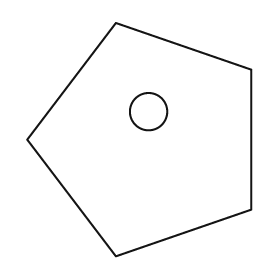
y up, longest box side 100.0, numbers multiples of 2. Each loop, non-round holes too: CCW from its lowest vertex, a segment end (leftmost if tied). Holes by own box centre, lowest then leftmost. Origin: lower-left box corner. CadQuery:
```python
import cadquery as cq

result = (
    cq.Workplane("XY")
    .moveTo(38.0, 0.0)
    .lineTo(96.0, 20.0)
    .lineTo(96.0, 80.0)
    .lineTo(38.0, 100.0)
    .lineTo(0.0, 50.0)
    .close()
    .moveTo(52.0, 62.0)
    .circle(8.0)
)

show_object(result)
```